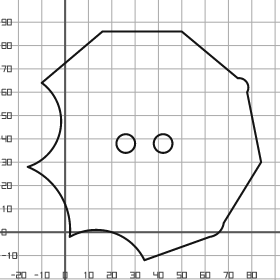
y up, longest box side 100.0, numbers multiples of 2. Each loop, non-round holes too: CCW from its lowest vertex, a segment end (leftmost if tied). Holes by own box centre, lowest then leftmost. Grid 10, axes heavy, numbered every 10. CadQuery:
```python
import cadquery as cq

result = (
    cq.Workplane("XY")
    .moveTo(34.0, -12.0)
    .lineTo(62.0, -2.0)
    .threePointArc((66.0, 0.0), (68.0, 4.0))
    .lineTo(84.0, 30.0)
    .lineTo(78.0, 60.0)
    .threePointArc((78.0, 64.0), (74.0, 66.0))
    .lineTo(50.0, 86.0)
    .lineTo(16.0, 86.0)
    .lineTo(-10.0, 64.0)
    .threePointArc((-2.0, 44.0), (-16.0, 28.0))
    .threePointArc((-2.0, 16.0), (2.0, -2.0))
    .threePointArc((20.0, 0.0), (34.0, -12.0))
    .close()
    .moveTo(26.0, 38.0)
    .circle(4.0)
    .moveTo(42.0, 38.0)
    .circle(4.0)
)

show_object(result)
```